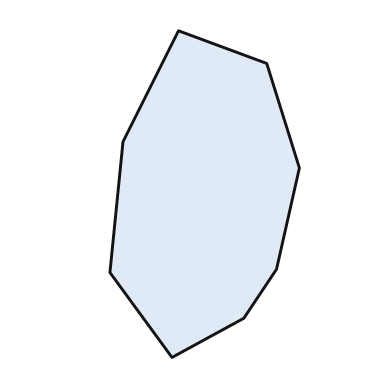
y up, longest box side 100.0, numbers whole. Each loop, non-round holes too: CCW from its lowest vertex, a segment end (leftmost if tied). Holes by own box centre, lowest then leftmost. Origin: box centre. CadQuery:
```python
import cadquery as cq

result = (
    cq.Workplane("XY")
    .moveTo(-10.0, -50.0)
    .lineTo(12.0, -38.0)
    .lineTo(22.0, -23.0)
    .lineTo(29.0, 8.0)
    .lineTo(19.0, 40.0)
    .lineTo(-8.0, 50.0)
    .lineTo(-25.0, 16.0)
    .lineTo(-29.0, -24.0)
    .close()
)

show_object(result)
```